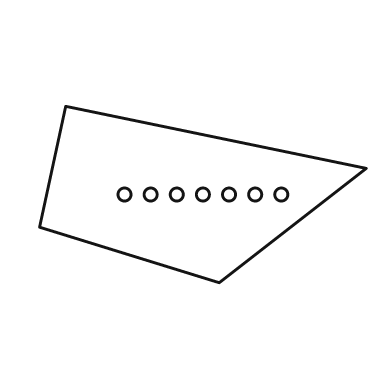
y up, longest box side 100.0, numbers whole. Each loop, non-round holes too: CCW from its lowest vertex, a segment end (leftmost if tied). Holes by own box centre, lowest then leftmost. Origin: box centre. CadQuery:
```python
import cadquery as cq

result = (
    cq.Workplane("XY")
    .moveTo(5.0, -27.0)
    .lineTo(50.0, 8.0)
    .lineTo(-42.0, 27.0)
    .lineTo(-50.0, -10.0)
    .close()
    .moveTo(-24.0, 0.0)
    .circle(2.0)
    .moveTo(-16.0, 0.0)
    .circle(2.0)
    .moveTo(-8.0, 0.0)
    .circle(2.0)
    .moveTo(0.0, 0.0)
    .circle(2.0)
    .moveTo(8.0, 0.0)
    .circle(2.0)
    .moveTo(16.0, 0.0)
    .circle(2.0)
    .moveTo(24.0, 0.0)
    .circle(2.0)
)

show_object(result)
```